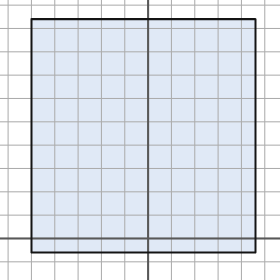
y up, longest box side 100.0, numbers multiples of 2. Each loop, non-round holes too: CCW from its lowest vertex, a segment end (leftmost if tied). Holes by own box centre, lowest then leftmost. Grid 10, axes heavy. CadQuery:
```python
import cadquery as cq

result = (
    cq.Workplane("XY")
    .moveTo(-50.0, -6.0)
    .lineTo(46.0, -6.0)
    .lineTo(46.0, 94.0)
    .lineTo(-50.0, 94.0)
    .close()
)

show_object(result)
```